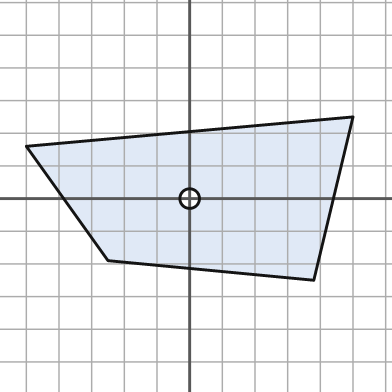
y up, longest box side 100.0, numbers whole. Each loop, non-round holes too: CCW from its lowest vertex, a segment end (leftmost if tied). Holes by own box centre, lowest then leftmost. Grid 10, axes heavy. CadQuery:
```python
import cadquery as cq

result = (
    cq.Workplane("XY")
    .moveTo(38.0, -25.0)
    .lineTo(50.0, 25.0)
    .lineTo(-50.0, 16.0)
    .lineTo(-25.0, -19.0)
    .close()
    .moveTo(0.0, 0.0)
    .circle(3.0)
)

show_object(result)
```